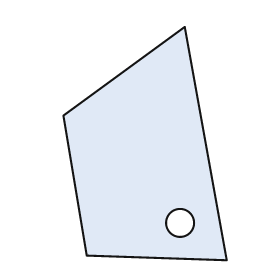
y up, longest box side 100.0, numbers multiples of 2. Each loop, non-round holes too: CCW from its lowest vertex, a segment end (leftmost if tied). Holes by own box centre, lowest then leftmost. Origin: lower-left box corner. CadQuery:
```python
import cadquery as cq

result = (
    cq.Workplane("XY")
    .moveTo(70.0, 0.0)
    .lineTo(52.0, 100.0)
    .lineTo(0.0, 62.0)
    .lineTo(10.0, 2.0)
    .close()
    .moveTo(50.0, 16.0)
    .circle(6.0)
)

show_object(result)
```